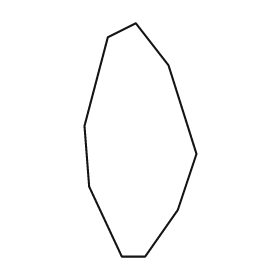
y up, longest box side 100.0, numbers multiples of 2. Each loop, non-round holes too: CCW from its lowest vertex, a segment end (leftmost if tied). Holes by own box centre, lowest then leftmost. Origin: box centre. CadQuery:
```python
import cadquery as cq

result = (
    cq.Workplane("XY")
    .moveTo(-8.0, -50.0)
    .lineTo(2.0, -50.0)
    .lineTo(16.0, -30.0)
    .lineTo(24.0, -6.0)
    .lineTo(12.0, 32.0)
    .lineTo(-2.0, 50.0)
    .lineTo(-14.0, 44.0)
    .lineTo(-24.0, 6.0)
    .lineTo(-22.0, -20.0)
    .close()
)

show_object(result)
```